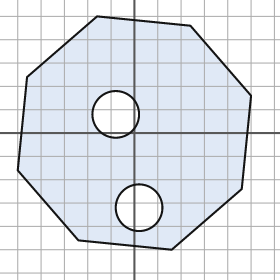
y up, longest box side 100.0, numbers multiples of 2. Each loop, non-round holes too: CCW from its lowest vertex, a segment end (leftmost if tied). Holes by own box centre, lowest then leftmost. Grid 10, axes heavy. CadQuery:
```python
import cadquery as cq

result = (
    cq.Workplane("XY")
    .moveTo(16.0, -50.0)
    .lineTo(46.0, -24.0)
    .lineTo(50.0, 16.0)
    .lineTo(24.0, 46.0)
    .lineTo(-16.0, 50.0)
    .lineTo(-46.0, 24.0)
    .lineTo(-50.0, -16.0)
    .lineTo(-24.0, -46.0)
    .close()
    .moveTo(2.0, -32.0)
    .circle(10.0)
    .moveTo(-8.0, 8.0)
    .circle(10.0)
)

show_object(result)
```